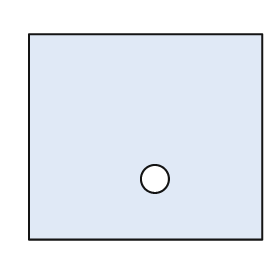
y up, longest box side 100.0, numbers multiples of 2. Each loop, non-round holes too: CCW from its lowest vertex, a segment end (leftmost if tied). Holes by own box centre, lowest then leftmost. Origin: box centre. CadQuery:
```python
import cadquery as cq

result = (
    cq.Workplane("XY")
    .moveTo(-50.0, -44.0)
    .lineTo(50.0, -44.0)
    .lineTo(50.0, 44.0)
    .lineTo(-50.0, 44.0)
    .close()
    .moveTo(4.0, -18.0)
    .circle(6.0)
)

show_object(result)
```